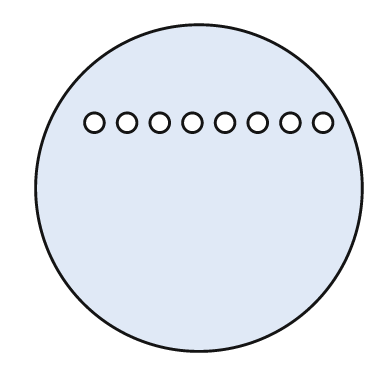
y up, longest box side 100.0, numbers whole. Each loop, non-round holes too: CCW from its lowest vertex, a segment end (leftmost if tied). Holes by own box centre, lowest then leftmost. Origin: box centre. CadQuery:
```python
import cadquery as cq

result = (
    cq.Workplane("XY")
    .moveTo(0.0, 0.0)
    .circle(50.0)
    .moveTo(-32.0, 20.0)
    .circle(3.0)
    .moveTo(-22.0, 20.0)
    .circle(3.0)
    .moveTo(-12.0, 20.0)
    .circle(3.0)
    .moveTo(-2.0, 20.0)
    .circle(3.0)
    .moveTo(8.0, 20.0)
    .circle(3.0)
    .moveTo(18.0, 20.0)
    .circle(3.0)
    .moveTo(28.0, 20.0)
    .circle(3.0)
    .moveTo(38.0, 20.0)
    .circle(3.0)
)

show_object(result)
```